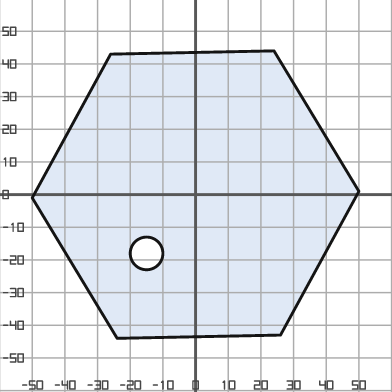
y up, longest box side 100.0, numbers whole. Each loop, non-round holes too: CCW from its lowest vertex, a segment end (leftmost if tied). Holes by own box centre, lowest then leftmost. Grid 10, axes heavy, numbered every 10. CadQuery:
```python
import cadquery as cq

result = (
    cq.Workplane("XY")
    .moveTo(-24.0, -44.0)
    .lineTo(26.0, -43.0)
    .lineTo(50.0, 1.0)
    .lineTo(24.0, 44.0)
    .lineTo(-26.0, 43.0)
    .lineTo(-50.0, -1.0)
    .close()
    .moveTo(-15.0, -18.0)
    .circle(5.0)
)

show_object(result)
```